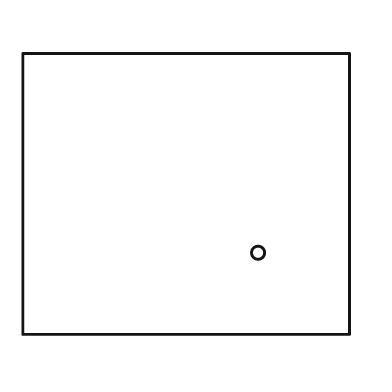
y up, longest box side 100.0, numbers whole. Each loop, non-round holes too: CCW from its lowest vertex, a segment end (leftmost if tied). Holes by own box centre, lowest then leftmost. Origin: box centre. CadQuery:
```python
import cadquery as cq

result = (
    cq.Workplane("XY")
    .moveTo(-50.0, -43.0)
    .lineTo(50.0, -43.0)
    .lineTo(50.0, 43.0)
    .lineTo(-50.0, 43.0)
    .close()
    .moveTo(22.0, -18.0)
    .circle(2.0)
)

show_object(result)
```